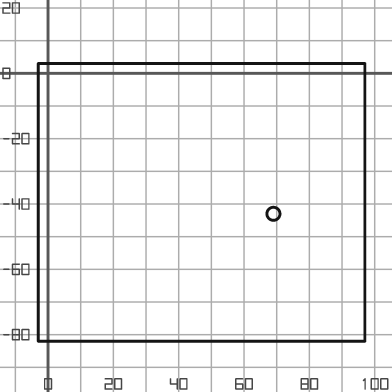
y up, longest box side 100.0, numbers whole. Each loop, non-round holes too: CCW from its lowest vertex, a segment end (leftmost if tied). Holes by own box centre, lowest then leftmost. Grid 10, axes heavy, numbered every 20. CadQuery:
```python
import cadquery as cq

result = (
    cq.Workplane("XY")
    .moveTo(-3.0, -82.0)
    .lineTo(97.0, -82.0)
    .lineTo(97.0, 3.0)
    .lineTo(-3.0, 3.0)
    .close()
    .moveTo(69.0, -43.0)
    .circle(2.0)
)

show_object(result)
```